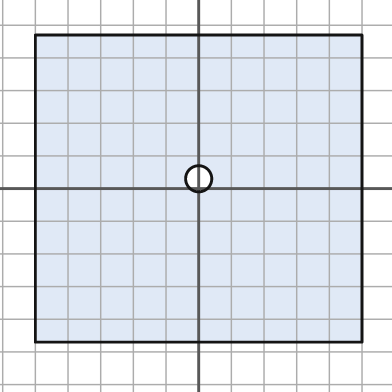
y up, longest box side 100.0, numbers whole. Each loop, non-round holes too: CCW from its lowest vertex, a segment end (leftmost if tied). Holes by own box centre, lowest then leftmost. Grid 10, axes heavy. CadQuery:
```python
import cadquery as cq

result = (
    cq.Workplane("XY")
    .moveTo(-50.0, -47.0)
    .lineTo(50.0, -47.0)
    .lineTo(50.0, 47.0)
    .lineTo(-50.0, 47.0)
    .close()
    .moveTo(0.0, 3.0)
    .circle(4.0)
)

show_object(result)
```